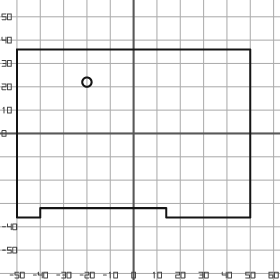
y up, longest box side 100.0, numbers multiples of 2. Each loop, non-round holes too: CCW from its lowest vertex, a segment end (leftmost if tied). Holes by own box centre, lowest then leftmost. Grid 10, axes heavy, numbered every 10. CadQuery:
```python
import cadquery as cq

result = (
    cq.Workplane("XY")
    .moveTo(-50.0, -36.0)
    .lineTo(-40.0, -36.0)
    .lineTo(-40.0, -32.0)
    .lineTo(14.0, -32.0)
    .lineTo(14.0, -36.0)
    .lineTo(50.0, -36.0)
    .lineTo(50.0, 36.0)
    .lineTo(-50.0, 36.0)
    .close()
    .moveTo(-20.0, 22.0)
    .circle(2.0)
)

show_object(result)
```